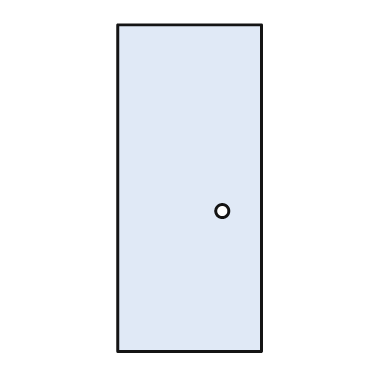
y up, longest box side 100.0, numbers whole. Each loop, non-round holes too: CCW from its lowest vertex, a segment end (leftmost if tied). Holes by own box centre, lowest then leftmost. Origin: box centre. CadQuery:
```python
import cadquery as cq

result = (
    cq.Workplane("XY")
    .moveTo(-22.0, -50.0)
    .lineTo(22.0, -50.0)
    .lineTo(22.0, 50.0)
    .lineTo(-22.0, 50.0)
    .close()
    .moveTo(10.0, -7.0)
    .circle(2.0)
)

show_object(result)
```